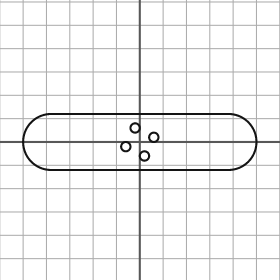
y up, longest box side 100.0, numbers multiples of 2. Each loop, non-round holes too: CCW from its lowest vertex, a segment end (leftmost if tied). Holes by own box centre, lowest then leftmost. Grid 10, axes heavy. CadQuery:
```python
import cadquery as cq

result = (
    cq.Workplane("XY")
    .moveTo(-38.0, -12.0)
    .lineTo(38.0, -12.0)
    .threePointArc((50.0, 0.0), (38.0, 12.0))
    .lineTo(-38.0, 12.0)
    .threePointArc((-50.0, 0.0), (-38.0, -12.0))
    .close()
    .moveTo(2.0, -6.0)
    .circle(2.0)
    .moveTo(-6.0, -2.0)
    .circle(2.0)
    .moveTo(6.0, 2.0)
    .circle(2.0)
    .moveTo(-2.0, 6.0)
    .circle(2.0)
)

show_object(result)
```